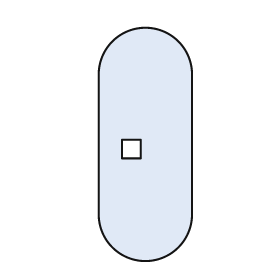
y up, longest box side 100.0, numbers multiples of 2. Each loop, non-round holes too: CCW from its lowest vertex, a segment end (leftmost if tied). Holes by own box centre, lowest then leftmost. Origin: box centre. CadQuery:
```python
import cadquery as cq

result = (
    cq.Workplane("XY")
    .moveTo(-20.0, -30.0)
    .threePointArc((0.0, -50.0), (20.0, -30.0))
    .lineTo(20.0, 30.0)
    .threePointArc((0.0, 50.0), (-20.0, 30.0))
    .close()
    .moveTo(-10.0, -6.0)
    .lineTo(-2.0, -6.0)
    .lineTo(-2.0, 2.0)
    .lineTo(-10.0, 2.0)
    .close()
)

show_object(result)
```